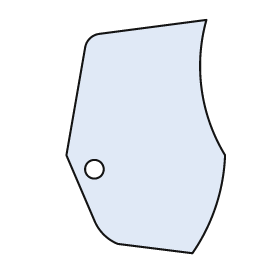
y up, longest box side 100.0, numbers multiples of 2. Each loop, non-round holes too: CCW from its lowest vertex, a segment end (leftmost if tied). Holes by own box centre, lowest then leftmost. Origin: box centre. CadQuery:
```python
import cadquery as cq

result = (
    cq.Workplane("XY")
    .moveTo(20.0, -50.0)
    .threePointArc((30.0, -30.0), (34.0, -8.0))
    .threePointArc((24.0, 20.0), (26.0, 50.0))
    .lineTo(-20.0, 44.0)
    .threePointArc((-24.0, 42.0), (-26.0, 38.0))
    .lineTo(-34.0, -8.0)
    .lineTo(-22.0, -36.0)
    .threePointArc((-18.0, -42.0), (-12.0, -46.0))
    .close()
    .moveTo(-22.0, -14.0)
    .circle(4.0)
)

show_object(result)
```